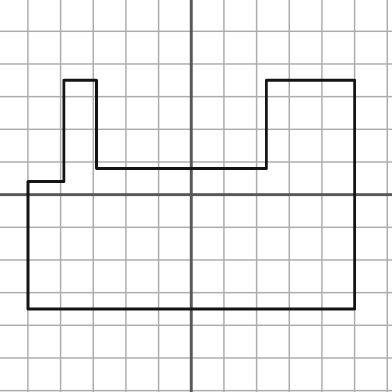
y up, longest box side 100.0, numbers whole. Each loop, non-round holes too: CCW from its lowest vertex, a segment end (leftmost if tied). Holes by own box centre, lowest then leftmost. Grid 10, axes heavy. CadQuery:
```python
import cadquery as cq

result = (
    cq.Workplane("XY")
    .moveTo(-50.0, -35.0)
    .lineTo(50.0, -35.0)
    .lineTo(50.0, 35.0)
    .lineTo(23.0, 35.0)
    .lineTo(23.0, 8.0)
    .lineTo(-29.0, 8.0)
    .lineTo(-29.0, 35.0)
    .lineTo(-39.0, 35.0)
    .lineTo(-39.0, 4.0)
    .lineTo(-50.0, 4.0)
    .close()
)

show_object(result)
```